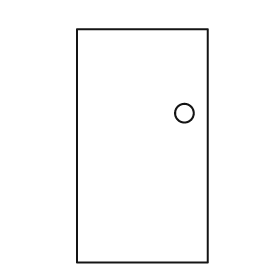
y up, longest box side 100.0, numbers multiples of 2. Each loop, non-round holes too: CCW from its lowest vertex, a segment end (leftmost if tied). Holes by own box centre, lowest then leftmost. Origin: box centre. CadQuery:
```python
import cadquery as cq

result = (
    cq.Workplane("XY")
    .moveTo(-28.0, -50.0)
    .lineTo(28.0, -50.0)
    .lineTo(28.0, 50.0)
    .lineTo(-28.0, 50.0)
    .close()
    .moveTo(18.0, 14.0)
    .circle(4.0)
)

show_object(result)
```